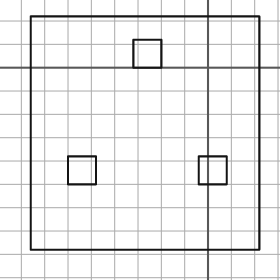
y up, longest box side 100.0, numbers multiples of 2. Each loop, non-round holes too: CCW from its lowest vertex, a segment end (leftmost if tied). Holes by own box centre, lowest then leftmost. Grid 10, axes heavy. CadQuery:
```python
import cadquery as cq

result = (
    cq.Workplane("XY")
    .moveTo(-76.0, -78.0)
    .lineTo(22.0, -78.0)
    .lineTo(22.0, 22.0)
    .lineTo(-76.0, 22.0)
    .close()
    .moveTo(-60.0, -50.0)
    .lineTo(-48.0, -50.0)
    .lineTo(-48.0, -38.0)
    .lineTo(-60.0, -38.0)
    .close()
    .moveTo(-4.0, -50.0)
    .lineTo(8.0, -50.0)
    .lineTo(8.0, -38.0)
    .lineTo(-4.0, -38.0)
    .close()
    .moveTo(-32.0, 0.0)
    .lineTo(-20.0, 0.0)
    .lineTo(-20.0, 12.0)
    .lineTo(-32.0, 12.0)
    .close()
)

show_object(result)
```